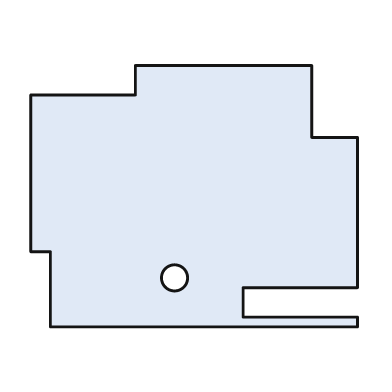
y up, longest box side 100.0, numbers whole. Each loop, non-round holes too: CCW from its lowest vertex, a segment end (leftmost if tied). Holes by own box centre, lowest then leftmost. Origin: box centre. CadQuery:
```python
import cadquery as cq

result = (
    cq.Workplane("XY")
    .moveTo(-44.0, -40.0)
    .lineTo(50.0, -40.0)
    .lineTo(50.0, -37.0)
    .lineTo(15.0, -37.0)
    .lineTo(15.0, -28.0)
    .lineTo(50.0, -28.0)
    .lineTo(50.0, 18.0)
    .lineTo(36.0, 18.0)
    .lineTo(36.0, 40.0)
    .lineTo(-18.0, 40.0)
    .lineTo(-18.0, 31.0)
    .lineTo(-50.0, 31.0)
    .lineTo(-50.0, -17.0)
    .lineTo(-44.0, -17.0)
    .close()
    .moveTo(-6.0, -25.0)
    .circle(4.0)
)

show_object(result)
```